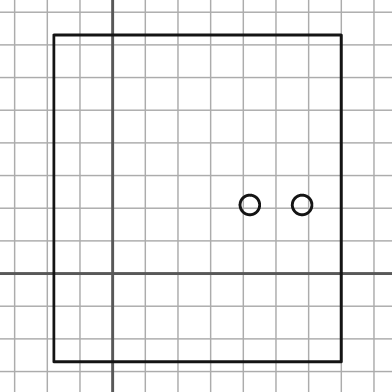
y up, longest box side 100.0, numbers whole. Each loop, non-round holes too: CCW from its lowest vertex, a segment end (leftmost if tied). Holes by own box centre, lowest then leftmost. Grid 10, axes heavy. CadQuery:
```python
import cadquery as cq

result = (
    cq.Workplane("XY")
    .moveTo(-18.0, -27.0)
    .lineTo(70.0, -27.0)
    .lineTo(70.0, 73.0)
    .lineTo(-18.0, 73.0)
    .close()
    .moveTo(42.0, 21.0)
    .circle(3.0)
    .moveTo(58.0, 21.0)
    .circle(3.0)
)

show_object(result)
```